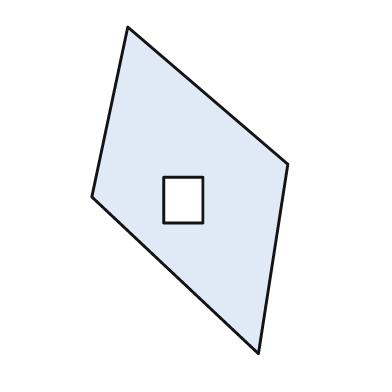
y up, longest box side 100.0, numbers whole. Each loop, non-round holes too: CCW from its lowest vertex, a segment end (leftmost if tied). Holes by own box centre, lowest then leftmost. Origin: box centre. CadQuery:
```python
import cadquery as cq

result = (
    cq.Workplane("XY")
    .moveTo(21.0, -50.0)
    .lineTo(30.0, 8.0)
    .lineTo(-19.0, 50.0)
    .lineTo(-30.0, -2.0)
    .close()
    .moveTo(-8.0, -10.0)
    .lineTo(4.0, -10.0)
    .lineTo(4.0, 4.0)
    .lineTo(-8.0, 4.0)
    .close()
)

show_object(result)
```